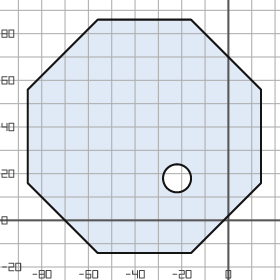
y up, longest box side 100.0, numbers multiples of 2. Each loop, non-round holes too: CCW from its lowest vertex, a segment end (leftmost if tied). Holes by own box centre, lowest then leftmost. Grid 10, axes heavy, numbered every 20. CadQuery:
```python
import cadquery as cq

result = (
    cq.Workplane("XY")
    .moveTo(-56.0, -14.0)
    .lineTo(-16.0, -14.0)
    .lineTo(14.0, 16.0)
    .lineTo(14.0, 56.0)
    .lineTo(-16.0, 86.0)
    .lineTo(-56.0, 86.0)
    .lineTo(-86.0, 56.0)
    .lineTo(-86.0, 16.0)
    .close()
    .moveTo(-22.0, 18.0)
    .circle(6.0)
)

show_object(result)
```